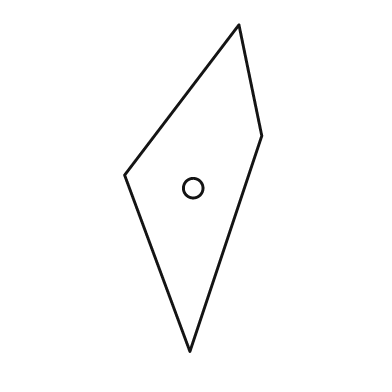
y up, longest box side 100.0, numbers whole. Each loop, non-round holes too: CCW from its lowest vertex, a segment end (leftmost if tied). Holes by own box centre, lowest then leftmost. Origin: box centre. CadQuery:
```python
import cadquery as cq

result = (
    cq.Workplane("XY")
    .moveTo(-1.0, -50.0)
    .lineTo(21.0, 16.0)
    .lineTo(14.0, 50.0)
    .lineTo(-21.0, 4.0)
    .close()
    .moveTo(0.0, 0.0)
    .circle(3.0)
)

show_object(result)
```